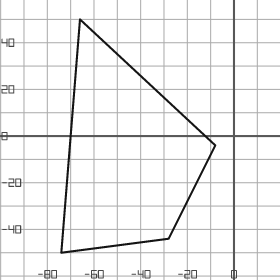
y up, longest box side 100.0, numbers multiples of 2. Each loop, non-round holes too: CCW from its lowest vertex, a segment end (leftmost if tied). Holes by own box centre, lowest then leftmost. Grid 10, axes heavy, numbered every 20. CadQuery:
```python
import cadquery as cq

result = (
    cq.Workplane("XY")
    .moveTo(-74.0, -50.0)
    .lineTo(-28.0, -44.0)
    .lineTo(-8.0, -4.0)
    .lineTo(-66.0, 50.0)
    .close()
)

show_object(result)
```